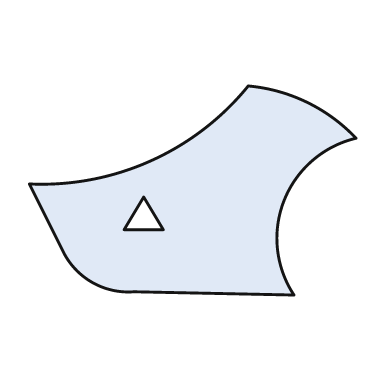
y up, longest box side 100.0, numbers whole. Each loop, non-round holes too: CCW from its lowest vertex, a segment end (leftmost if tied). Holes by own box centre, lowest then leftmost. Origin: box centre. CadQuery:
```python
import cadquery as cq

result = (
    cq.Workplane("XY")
    .moveTo(31.0, -32.0)
    .threePointArc((28.0, -3.0), (50.0, 16.0))
    .threePointArc((35.0, 27.0), (17.0, 32.0))
    .threePointArc((-13.0, 9.0), (-50.0, 2.0))
    .lineTo(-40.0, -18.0)
    .threePointArc((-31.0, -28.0), (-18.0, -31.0))
    .close()
    .moveTo(-21.0, -12.0)
    .lineTo(-9.0, -12.0)
    .lineTo(-15.0, -2.0)
    .close()
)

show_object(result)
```